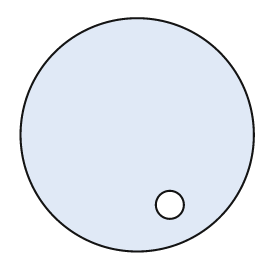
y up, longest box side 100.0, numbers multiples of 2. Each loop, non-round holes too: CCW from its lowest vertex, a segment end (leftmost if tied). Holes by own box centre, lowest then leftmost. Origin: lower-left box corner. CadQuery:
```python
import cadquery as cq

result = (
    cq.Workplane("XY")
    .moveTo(50.0, 50.0)
    .circle(50.0)
    .moveTo(64.0, 20.0)
    .circle(6.0)
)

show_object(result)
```